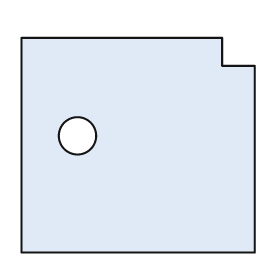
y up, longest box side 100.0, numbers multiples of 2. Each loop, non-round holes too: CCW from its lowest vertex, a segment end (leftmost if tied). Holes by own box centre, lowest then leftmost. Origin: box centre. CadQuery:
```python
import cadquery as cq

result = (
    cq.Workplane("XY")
    .moveTo(-50.0, -46.0)
    .lineTo(50.0, -46.0)
    .lineTo(50.0, 34.0)
    .lineTo(36.0, 34.0)
    .lineTo(36.0, 46.0)
    .lineTo(-50.0, 46.0)
    .close()
    .moveTo(-26.0, 4.0)
    .circle(8.0)
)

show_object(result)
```